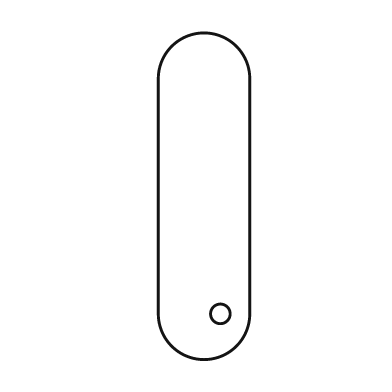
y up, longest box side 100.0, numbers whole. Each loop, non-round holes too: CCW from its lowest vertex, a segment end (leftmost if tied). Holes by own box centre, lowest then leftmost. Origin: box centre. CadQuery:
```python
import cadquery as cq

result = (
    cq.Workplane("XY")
    .moveTo(-14.0, -36.0)
    .threePointArc((0.0, -50.0), (14.0, -36.0))
    .lineTo(14.0, 36.0)
    .threePointArc((0.0, 50.0), (-14.0, 36.0))
    .close()
    .moveTo(5.0, -36.0)
    .circle(3.0)
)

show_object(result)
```